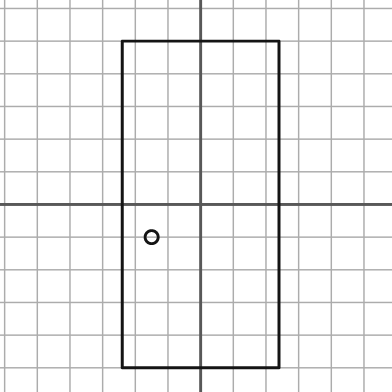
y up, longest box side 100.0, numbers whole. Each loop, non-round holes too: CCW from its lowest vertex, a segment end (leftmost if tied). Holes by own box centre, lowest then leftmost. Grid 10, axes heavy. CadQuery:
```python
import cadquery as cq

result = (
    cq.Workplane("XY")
    .moveTo(-24.0, -50.0)
    .lineTo(24.0, -50.0)
    .lineTo(24.0, 50.0)
    .lineTo(-24.0, 50.0)
    .close()
    .moveTo(-15.0, -10.0)
    .circle(2.0)
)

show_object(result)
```